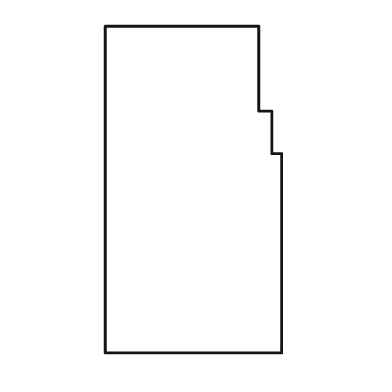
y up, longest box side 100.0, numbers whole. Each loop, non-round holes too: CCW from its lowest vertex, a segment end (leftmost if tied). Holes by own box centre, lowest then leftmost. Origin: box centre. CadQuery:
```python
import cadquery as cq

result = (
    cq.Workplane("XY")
    .moveTo(-27.0, -50.0)
    .lineTo(27.0, -50.0)
    .lineTo(27.0, 11.0)
    .lineTo(24.0, 11.0)
    .lineTo(24.0, 24.0)
    .lineTo(20.0, 24.0)
    .lineTo(20.0, 50.0)
    .lineTo(-27.0, 50.0)
    .close()
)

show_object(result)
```